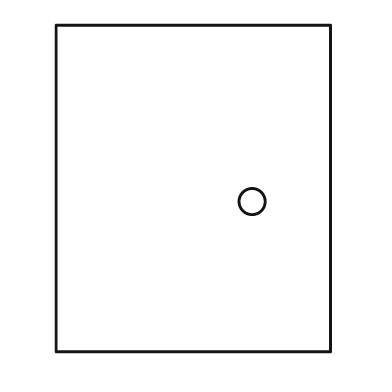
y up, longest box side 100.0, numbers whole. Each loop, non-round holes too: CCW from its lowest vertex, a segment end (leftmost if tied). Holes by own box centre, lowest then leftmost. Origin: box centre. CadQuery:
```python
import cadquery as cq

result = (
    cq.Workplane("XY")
    .moveTo(-42.0, -50.0)
    .lineTo(42.0, -50.0)
    .lineTo(42.0, 50.0)
    .lineTo(-42.0, 50.0)
    .close()
    .moveTo(18.0, -4.0)
    .circle(4.0)
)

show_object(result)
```